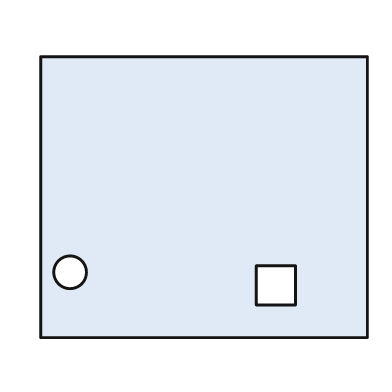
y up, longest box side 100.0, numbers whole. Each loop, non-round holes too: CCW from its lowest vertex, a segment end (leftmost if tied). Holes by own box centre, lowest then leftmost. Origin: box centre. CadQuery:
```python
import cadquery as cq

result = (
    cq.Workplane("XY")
    .moveTo(-50.0, -43.0)
    .lineTo(50.0, -43.0)
    .lineTo(50.0, 43.0)
    .lineTo(-50.0, 43.0)
    .close()
    .moveTo(16.0, -33.0)
    .lineTo(28.0, -33.0)
    .lineTo(28.0, -21.0)
    .lineTo(16.0, -21.0)
    .close()
    .moveTo(-41.0, -23.0)
    .circle(5.0)
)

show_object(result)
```